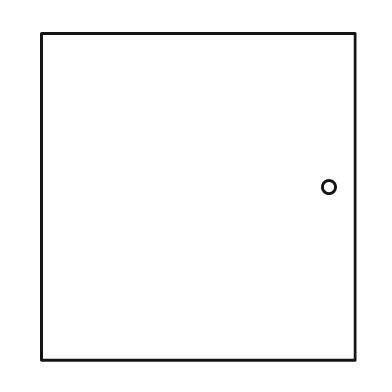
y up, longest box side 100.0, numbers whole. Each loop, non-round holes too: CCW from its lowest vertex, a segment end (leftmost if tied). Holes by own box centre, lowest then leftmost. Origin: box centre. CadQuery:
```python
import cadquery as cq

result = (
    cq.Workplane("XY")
    .moveTo(-48.0, -50.0)
    .lineTo(48.0, -50.0)
    .lineTo(48.0, 50.0)
    .lineTo(-48.0, 50.0)
    .close()
    .moveTo(40.0, 3.0)
    .circle(2.0)
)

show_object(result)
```